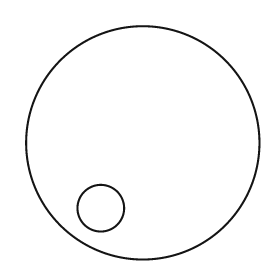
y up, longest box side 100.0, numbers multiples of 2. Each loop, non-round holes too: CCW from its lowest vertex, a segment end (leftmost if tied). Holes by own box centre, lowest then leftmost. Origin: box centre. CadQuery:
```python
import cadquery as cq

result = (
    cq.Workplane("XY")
    .moveTo(0.0, 0.0)
    .circle(50.0)
    .moveTo(-18.0, -28.0)
    .circle(10.0)
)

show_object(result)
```